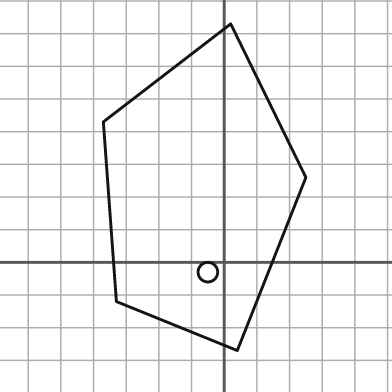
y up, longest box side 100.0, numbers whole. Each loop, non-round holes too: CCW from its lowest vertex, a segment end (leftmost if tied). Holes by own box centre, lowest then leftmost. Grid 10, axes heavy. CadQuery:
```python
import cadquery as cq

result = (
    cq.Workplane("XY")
    .moveTo(4.0, -27.0)
    .lineTo(25.0, 26.0)
    .lineTo(2.0, 73.0)
    .lineTo(-37.0, 43.0)
    .lineTo(-33.0, -12.0)
    .close()
    .moveTo(-5.0, -3.0)
    .circle(3.0)
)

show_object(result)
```